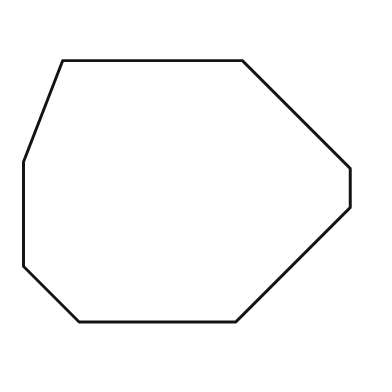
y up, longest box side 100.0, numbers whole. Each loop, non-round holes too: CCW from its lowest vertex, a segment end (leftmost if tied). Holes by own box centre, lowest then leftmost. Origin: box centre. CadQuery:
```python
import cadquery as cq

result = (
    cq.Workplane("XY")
    .moveTo(-33.0, -40.0)
    .lineTo(15.0, -40.0)
    .lineTo(50.0, -5.0)
    .lineTo(50.0, 7.0)
    .lineTo(17.0, 40.0)
    .lineTo(-38.0, 40.0)
    .lineTo(-50.0, 9.0)
    .lineTo(-50.0, -23.0)
    .close()
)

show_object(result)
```